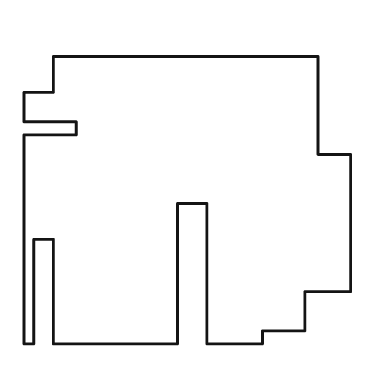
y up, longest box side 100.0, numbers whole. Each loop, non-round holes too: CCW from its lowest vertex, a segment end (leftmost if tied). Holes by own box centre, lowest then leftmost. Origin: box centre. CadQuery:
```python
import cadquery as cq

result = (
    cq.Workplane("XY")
    .moveTo(-50.0, -44.0)
    .lineTo(-47.0, -44.0)
    .lineTo(-47.0, -12.0)
    .lineTo(-41.0, -12.0)
    .lineTo(-41.0, -44.0)
    .lineTo(-3.0, -44.0)
    .lineTo(-3.0, -1.0)
    .lineTo(6.0, -1.0)
    .lineTo(6.0, -44.0)
    .lineTo(23.0, -44.0)
    .lineTo(23.0, -40.0)
    .lineTo(36.0, -40.0)
    .lineTo(36.0, -28.0)
    .lineTo(50.0, -28.0)
    .lineTo(50.0, 14.0)
    .lineTo(40.0, 14.0)
    .lineTo(40.0, 44.0)
    .lineTo(-41.0, 44.0)
    .lineTo(-41.0, 33.0)
    .lineTo(-50.0, 33.0)
    .lineTo(-50.0, 24.0)
    .lineTo(-34.0, 24.0)
    .lineTo(-34.0, 20.0)
    .lineTo(-50.0, 20.0)
    .close()
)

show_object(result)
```